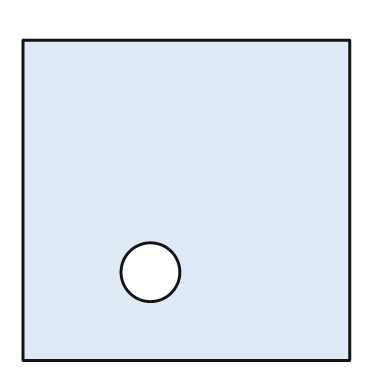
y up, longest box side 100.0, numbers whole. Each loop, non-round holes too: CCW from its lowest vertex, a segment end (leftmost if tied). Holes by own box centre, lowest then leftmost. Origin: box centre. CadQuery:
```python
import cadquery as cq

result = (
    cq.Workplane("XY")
    .moveTo(-50.0, -49.0)
    .lineTo(50.0, -49.0)
    .lineTo(50.0, 49.0)
    .lineTo(-50.0, 49.0)
    .close()
    .moveTo(-11.0, -22.0)
    .circle(9.0)
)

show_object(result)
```